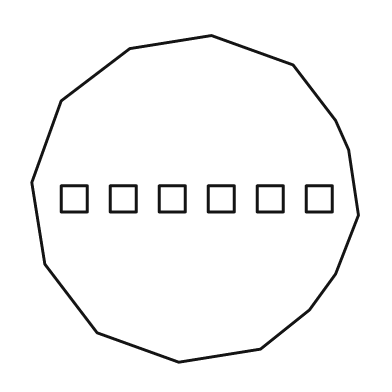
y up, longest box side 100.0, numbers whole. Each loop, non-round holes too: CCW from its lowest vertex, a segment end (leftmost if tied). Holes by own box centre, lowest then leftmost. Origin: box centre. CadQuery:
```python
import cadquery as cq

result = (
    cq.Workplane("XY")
    .moveTo(-5.0, -50.0)
    .lineTo(20.0, -46.0)
    .lineTo(35.0, -34.0)
    .lineTo(43.0, -23.0)
    .lineTo(50.0, -5.0)
    .lineTo(47.0, 15.0)
    .lineTo(43.0, 24.0)
    .lineTo(30.0, 41.0)
    .lineTo(5.0, 50.0)
    .lineTo(-20.0, 46.0)
    .lineTo(-41.0, 30.0)
    .lineTo(-50.0, 5.0)
    .lineTo(-46.0, -20.0)
    .lineTo(-30.0, -41.0)
    .close()
    .moveTo(-41.0, -4.0)
    .lineTo(-33.0, -4.0)
    .lineTo(-33.0, 4.0)
    .lineTo(-41.0, 4.0)
    .close()
    .moveTo(-26.0, -4.0)
    .lineTo(-18.0, -4.0)
    .lineTo(-18.0, 4.0)
    .lineTo(-26.0, 4.0)
    .close()
    .moveTo(-11.0, -4.0)
    .lineTo(-3.0, -4.0)
    .lineTo(-3.0, 4.0)
    .lineTo(-11.0, 4.0)
    .close()
    .moveTo(4.0, -4.0)
    .lineTo(12.0, -4.0)
    .lineTo(12.0, 4.0)
    .lineTo(4.0, 4.0)
    .close()
    .moveTo(19.0, -4.0)
    .lineTo(27.0, -4.0)
    .lineTo(27.0, 4.0)
    .lineTo(19.0, 4.0)
    .close()
    .moveTo(34.0, -4.0)
    .lineTo(42.0, -4.0)
    .lineTo(42.0, 4.0)
    .lineTo(34.0, 4.0)
    .close()
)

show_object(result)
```